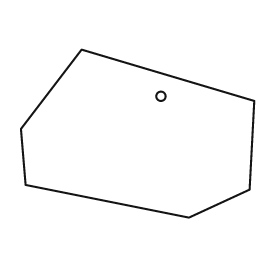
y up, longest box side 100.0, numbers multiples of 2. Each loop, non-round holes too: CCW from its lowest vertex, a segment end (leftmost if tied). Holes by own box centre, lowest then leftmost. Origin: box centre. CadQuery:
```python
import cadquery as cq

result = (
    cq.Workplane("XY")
    .moveTo(22.0, -36.0)
    .lineTo(48.0, -24.0)
    .lineTo(50.0, 14.0)
    .lineTo(-24.0, 36.0)
    .lineTo(-50.0, 2.0)
    .lineTo(-48.0, -22.0)
    .close()
    .moveTo(10.0, 16.0)
    .circle(2.0)
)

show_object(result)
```